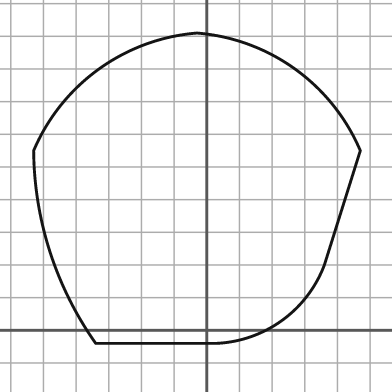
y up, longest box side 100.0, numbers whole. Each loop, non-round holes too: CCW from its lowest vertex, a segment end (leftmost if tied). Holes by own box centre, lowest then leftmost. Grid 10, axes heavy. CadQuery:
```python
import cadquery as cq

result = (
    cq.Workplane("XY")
    .moveTo(-34.0, -4.0)
    .lineTo(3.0, -4.0)
    .threePointArc((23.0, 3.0), (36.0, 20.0))
    .lineTo(47.0, 55.0)
    .threePointArc((27.0, 80.0), (-3.0, 91.0))
    .threePointArc((-33.0, 80.0), (-53.0, 55.0))
    .threePointArc((-48.0, 24.0), (-34.0, -4.0))
    .close()
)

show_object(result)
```